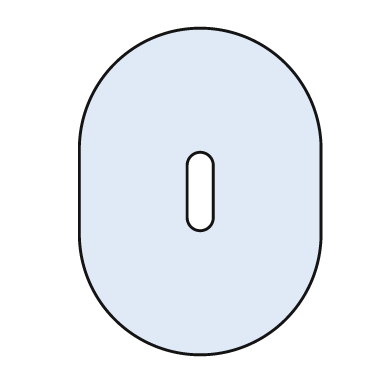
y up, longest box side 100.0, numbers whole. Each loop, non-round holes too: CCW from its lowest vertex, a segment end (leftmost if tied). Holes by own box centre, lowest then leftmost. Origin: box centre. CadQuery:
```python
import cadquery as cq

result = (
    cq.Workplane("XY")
    .moveTo(-37.0, -13.0)
    .threePointArc((0.0, -50.0), (37.0, -13.0))
    .lineTo(37.0, 13.0)
    .threePointArc((0.0, 50.0), (-37.0, 13.0))
    .close()
    .moveTo(-4.0, -8.0)
    .threePointArc((0.0, -12.0), (4.0, -8.0))
    .lineTo(4.0, 8.0)
    .threePointArc((0.0, 12.0), (-4.0, 8.0))
    .close()
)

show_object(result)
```